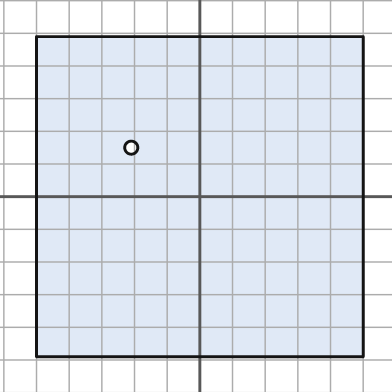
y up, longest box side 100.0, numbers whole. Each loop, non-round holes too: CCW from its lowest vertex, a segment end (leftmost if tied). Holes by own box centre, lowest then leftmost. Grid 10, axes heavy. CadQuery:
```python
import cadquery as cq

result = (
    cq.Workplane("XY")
    .moveTo(-50.0, -49.0)
    .lineTo(50.0, -49.0)
    .lineTo(50.0, 49.0)
    .lineTo(-50.0, 49.0)
    .close()
    .moveTo(-21.0, 15.0)
    .circle(2.0)
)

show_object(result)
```